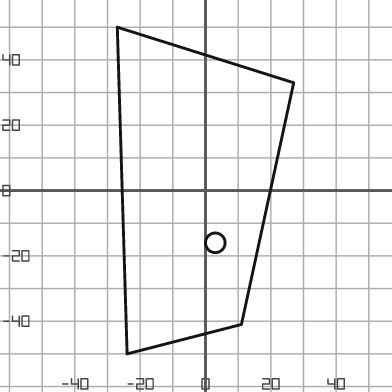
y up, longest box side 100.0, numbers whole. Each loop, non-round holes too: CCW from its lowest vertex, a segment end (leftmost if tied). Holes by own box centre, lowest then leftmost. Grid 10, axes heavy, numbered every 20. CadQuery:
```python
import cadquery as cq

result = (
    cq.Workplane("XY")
    .moveTo(-24.0, -50.0)
    .lineTo(11.0, -41.0)
    .lineTo(27.0, 33.0)
    .lineTo(-27.0, 50.0)
    .close()
    .moveTo(3.0, -16.0)
    .circle(3.0)
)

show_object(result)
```